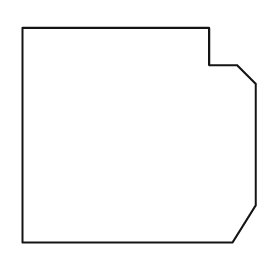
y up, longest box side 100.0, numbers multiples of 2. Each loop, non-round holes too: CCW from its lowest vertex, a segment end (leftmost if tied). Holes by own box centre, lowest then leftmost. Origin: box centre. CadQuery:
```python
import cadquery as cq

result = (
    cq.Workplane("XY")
    .moveTo(-50.0, -46.0)
    .lineTo(40.0, -46.0)
    .lineTo(50.0, -30.0)
    .lineTo(50.0, 22.0)
    .lineTo(42.0, 30.0)
    .lineTo(30.0, 30.0)
    .lineTo(30.0, 46.0)
    .lineTo(-50.0, 46.0)
    .close()
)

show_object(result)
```